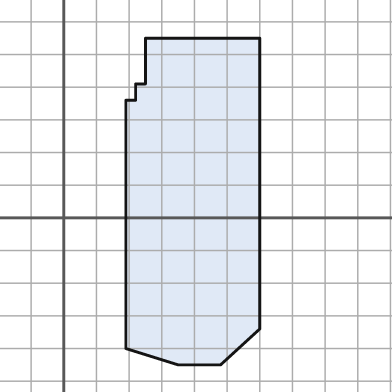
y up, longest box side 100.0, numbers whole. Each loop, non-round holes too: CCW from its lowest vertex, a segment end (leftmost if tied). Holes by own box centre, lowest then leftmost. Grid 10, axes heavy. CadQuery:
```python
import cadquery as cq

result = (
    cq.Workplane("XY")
    .moveTo(35.0, -45.0)
    .lineTo(48.0, -45.0)
    .lineTo(60.0, -34.0)
    .lineTo(60.0, 55.0)
    .lineTo(25.0, 55.0)
    .lineTo(25.0, 41.0)
    .lineTo(22.0, 41.0)
    .lineTo(22.0, 36.0)
    .lineTo(19.0, 36.0)
    .lineTo(19.0, -40.0)
    .close()
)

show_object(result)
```